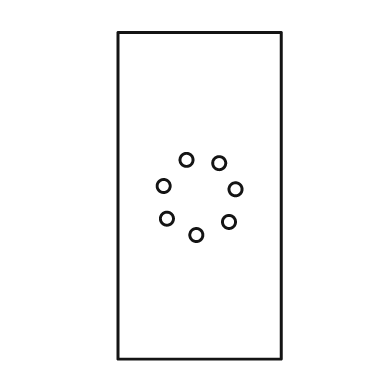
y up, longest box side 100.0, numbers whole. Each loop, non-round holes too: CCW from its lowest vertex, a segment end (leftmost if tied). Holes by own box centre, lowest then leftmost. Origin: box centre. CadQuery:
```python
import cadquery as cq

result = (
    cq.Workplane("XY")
    .moveTo(-25.0, -50.0)
    .lineTo(25.0, -50.0)
    .lineTo(25.0, 50.0)
    .lineTo(-25.0, 50.0)
    .close()
    .moveTo(-1.0, -12.0)
    .circle(2.0)
    .moveTo(9.0, -8.0)
    .circle(2.0)
    .moveTo(-10.0, -7.0)
    .circle(2.0)
    .moveTo(11.0, 2.0)
    .circle(2.0)
    .moveTo(-11.0, 3.0)
    .circle(2.0)
    .moveTo(6.0, 10.0)
    .circle(2.0)
    .moveTo(-4.0, 11.0)
    .circle(2.0)
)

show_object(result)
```